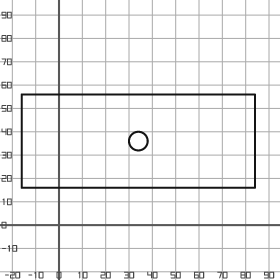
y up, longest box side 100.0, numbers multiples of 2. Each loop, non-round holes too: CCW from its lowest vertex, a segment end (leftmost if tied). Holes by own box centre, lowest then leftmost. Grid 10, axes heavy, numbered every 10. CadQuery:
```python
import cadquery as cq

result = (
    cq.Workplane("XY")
    .moveTo(-16.0, 16.0)
    .lineTo(84.0, 16.0)
    .lineTo(84.0, 56.0)
    .lineTo(-16.0, 56.0)
    .close()
    .moveTo(34.0, 36.0)
    .circle(4.0)
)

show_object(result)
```